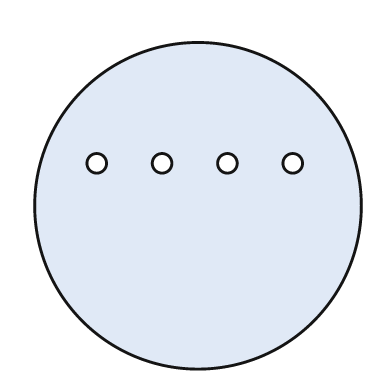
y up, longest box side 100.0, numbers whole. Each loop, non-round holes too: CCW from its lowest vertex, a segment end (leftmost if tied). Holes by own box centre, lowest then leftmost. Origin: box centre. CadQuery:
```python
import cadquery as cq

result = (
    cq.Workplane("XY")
    .moveTo(0.0, 0.0)
    .circle(50.0)
    .moveTo(-31.0, 13.0)
    .circle(3.0)
    .moveTo(-11.0, 13.0)
    .circle(3.0)
    .moveTo(9.0, 13.0)
    .circle(3.0)
    .moveTo(29.0, 13.0)
    .circle(3.0)
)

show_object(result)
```